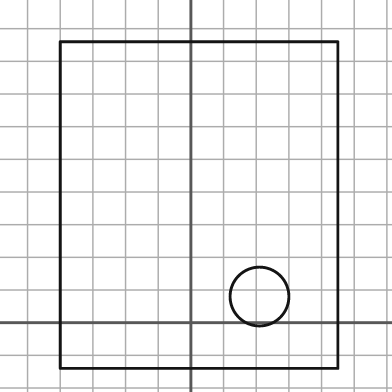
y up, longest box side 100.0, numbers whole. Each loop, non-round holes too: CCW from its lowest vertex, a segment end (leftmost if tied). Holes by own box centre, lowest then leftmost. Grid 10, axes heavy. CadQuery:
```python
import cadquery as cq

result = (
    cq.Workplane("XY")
    .moveTo(-40.0, -14.0)
    .lineTo(45.0, -14.0)
    .lineTo(45.0, 86.0)
    .lineTo(-40.0, 86.0)
    .close()
    .moveTo(21.0, 8.0)
    .circle(9.0)
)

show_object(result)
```